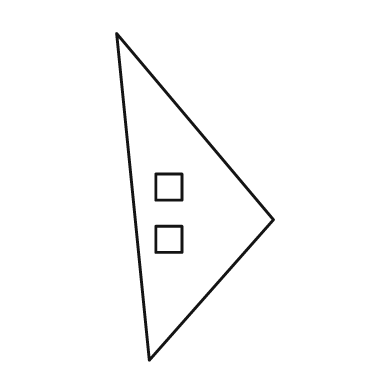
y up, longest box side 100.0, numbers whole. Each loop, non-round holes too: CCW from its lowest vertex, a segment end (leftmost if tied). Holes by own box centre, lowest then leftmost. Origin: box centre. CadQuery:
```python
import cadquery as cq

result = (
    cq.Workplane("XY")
    .moveTo(-14.0, -50.0)
    .lineTo(24.0, -7.0)
    .lineTo(-24.0, 50.0)
    .close()
    .moveTo(-12.0, -17.0)
    .lineTo(-4.0, -17.0)
    .lineTo(-4.0, -9.0)
    .lineTo(-12.0, -9.0)
    .close()
    .moveTo(-12.0, -1.0)
    .lineTo(-4.0, -1.0)
    .lineTo(-4.0, 7.0)
    .lineTo(-12.0, 7.0)
    .close()
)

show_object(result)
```